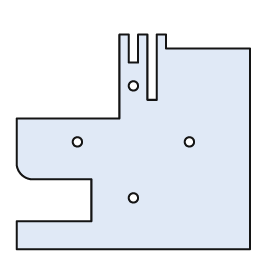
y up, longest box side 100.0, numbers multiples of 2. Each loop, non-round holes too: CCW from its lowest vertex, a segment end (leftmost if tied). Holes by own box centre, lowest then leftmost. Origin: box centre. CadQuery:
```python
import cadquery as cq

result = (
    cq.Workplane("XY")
    .moveTo(-50.0, -46.0)
    .lineTo(50.0, -46.0)
    .lineTo(50.0, 40.0)
    .lineTo(14.0, 40.0)
    .lineTo(14.0, 46.0)
    .lineTo(10.0, 46.0)
    .lineTo(10.0, 18.0)
    .lineTo(6.0, 18.0)
    .lineTo(6.0, 46.0)
    .lineTo(2.0, 46.0)
    .lineTo(2.0, 34.0)
    .lineTo(-2.0, 34.0)
    .lineTo(-2.0, 46.0)
    .lineTo(-6.0, 46.0)
    .lineTo(-6.0, 10.0)
    .lineTo(-50.0, 10.0)
    .lineTo(-50.0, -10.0)
    .threePointArc((-48.0, -14.0), (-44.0, -16.0))
    .lineTo(-18.0, -16.0)
    .lineTo(-18.0, -34.0)
    .lineTo(-50.0, -34.0)
    .close()
    .moveTo(0.0, -24.0)
    .circle(2.0)
    .moveTo(-24.0, 0.0)
    .circle(2.0)
    .moveTo(24.0, 0.0)
    .circle(2.0)
    .moveTo(0.0, 24.0)
    .circle(2.0)
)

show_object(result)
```